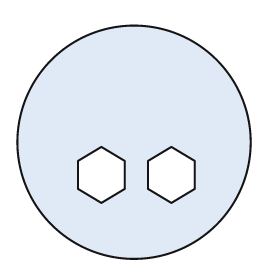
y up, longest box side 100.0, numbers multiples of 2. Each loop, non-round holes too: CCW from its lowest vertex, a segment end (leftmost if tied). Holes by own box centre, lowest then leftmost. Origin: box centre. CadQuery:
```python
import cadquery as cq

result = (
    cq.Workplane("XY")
    .moveTo(0.0, 0.0)
    .circle(50.0)
    .moveTo(-14.0, -26.0)
    .lineTo(-4.0, -20.0)
    .lineTo(-4.0, -8.0)
    .lineTo(-14.0, -2.0)
    .lineTo(-24.0, -8.0)
    .lineTo(-24.0, -20.0)
    .close()
    .moveTo(16.0, -26.0)
    .lineTo(26.0, -20.0)
    .lineTo(26.0, -8.0)
    .lineTo(16.0, -2.0)
    .lineTo(6.0, -8.0)
    .lineTo(6.0, -20.0)
    .close()
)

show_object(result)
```